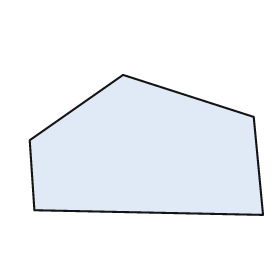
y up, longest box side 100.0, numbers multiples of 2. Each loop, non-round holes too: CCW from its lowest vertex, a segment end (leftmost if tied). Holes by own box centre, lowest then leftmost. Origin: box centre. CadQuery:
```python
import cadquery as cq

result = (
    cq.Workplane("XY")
    .moveTo(50.0, -30.0)
    .lineTo(46.0, 12.0)
    .lineTo(-10.0, 30.0)
    .lineTo(-50.0, 2.0)
    .lineTo(-48.0, -28.0)
    .close()
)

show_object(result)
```